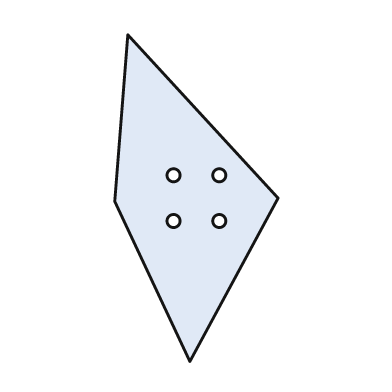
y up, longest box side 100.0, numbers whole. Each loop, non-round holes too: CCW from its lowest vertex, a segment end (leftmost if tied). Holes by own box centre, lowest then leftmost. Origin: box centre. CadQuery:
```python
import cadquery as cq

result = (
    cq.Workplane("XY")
    .moveTo(-2.0, -50.0)
    .lineTo(25.0, 0.0)
    .lineTo(-21.0, 50.0)
    .lineTo(-25.0, -1.0)
    .close()
    .moveTo(-7.0, -7.0)
    .circle(2.0)
    .moveTo(7.0, -7.0)
    .circle(2.0)
    .moveTo(-7.0, 7.0)
    .circle(2.0)
    .moveTo(7.0, 7.0)
    .circle(2.0)
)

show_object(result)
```